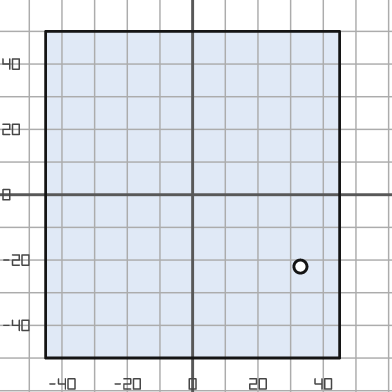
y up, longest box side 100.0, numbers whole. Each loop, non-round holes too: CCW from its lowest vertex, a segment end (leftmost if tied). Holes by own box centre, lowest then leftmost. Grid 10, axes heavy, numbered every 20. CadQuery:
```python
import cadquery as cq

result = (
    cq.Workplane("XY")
    .moveTo(-45.0, -50.0)
    .lineTo(45.0, -50.0)
    .lineTo(45.0, 50.0)
    .lineTo(-45.0, 50.0)
    .close()
    .moveTo(33.0, -22.0)
    .circle(2.0)
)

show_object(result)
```